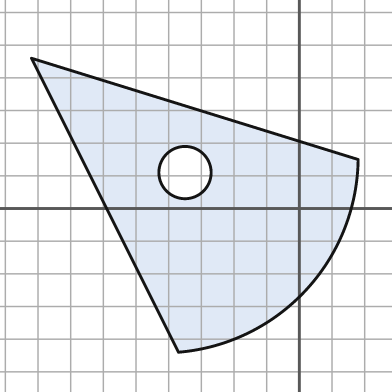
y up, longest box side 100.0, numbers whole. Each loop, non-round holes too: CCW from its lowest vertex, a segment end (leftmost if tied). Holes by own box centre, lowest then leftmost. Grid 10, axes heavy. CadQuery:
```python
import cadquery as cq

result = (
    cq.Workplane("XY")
    .moveTo(-37.0, -44.0)
    .threePointArc((2.0, -25.0), (18.0, 15.0))
    .lineTo(-82.0, 46.0)
    .close()
    .moveTo(-35.0, 11.0)
    .circle(8.0)
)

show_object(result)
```